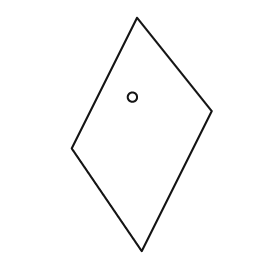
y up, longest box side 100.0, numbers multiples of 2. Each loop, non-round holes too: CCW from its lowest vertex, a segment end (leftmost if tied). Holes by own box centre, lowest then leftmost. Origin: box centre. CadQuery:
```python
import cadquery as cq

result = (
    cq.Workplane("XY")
    .moveTo(0.0, -50.0)
    .lineTo(30.0, 10.0)
    .lineTo(-2.0, 50.0)
    .lineTo(-30.0, -6.0)
    .close()
    .moveTo(-4.0, 16.0)
    .circle(2.0)
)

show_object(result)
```